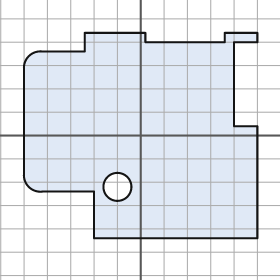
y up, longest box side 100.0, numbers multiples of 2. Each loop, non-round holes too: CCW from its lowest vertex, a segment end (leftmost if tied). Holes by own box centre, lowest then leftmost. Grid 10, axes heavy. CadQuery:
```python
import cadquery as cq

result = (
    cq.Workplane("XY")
    .moveTo(-20.0, -44.0)
    .lineTo(50.0, -44.0)
    .lineTo(50.0, 4.0)
    .lineTo(40.0, 4.0)
    .lineTo(40.0, 40.0)
    .lineTo(50.0, 40.0)
    .lineTo(50.0, 44.0)
    .lineTo(36.0, 44.0)
    .lineTo(36.0, 40.0)
    .lineTo(2.0, 40.0)
    .lineTo(2.0, 44.0)
    .lineTo(-24.0, 44.0)
    .lineTo(-24.0, 36.0)
    .lineTo(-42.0, 36.0)
    .threePointArc((-48.0, 34.0), (-50.0, 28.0))
    .lineTo(-50.0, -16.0)
    .threePointArc((-48.0, -22.0), (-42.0, -24.0))
    .lineTo(-20.0, -24.0)
    .close()
    .moveTo(-10.0, -22.0)
    .circle(6.0)
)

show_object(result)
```